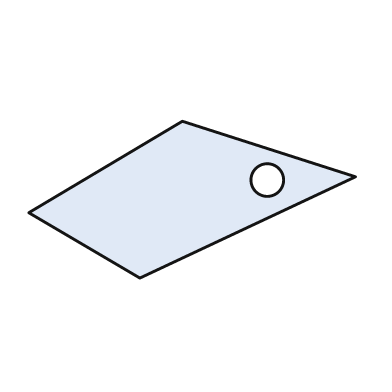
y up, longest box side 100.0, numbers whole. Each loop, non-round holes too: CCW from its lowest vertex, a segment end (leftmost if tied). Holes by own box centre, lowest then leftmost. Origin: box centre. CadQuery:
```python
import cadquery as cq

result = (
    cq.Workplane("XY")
    .moveTo(-16.0, -24.0)
    .lineTo(50.0, 7.0)
    .lineTo(-3.0, 24.0)
    .lineTo(-50.0, -4.0)
    .close()
    .moveTo(23.0, 6.0)
    .circle(5.0)
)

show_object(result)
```